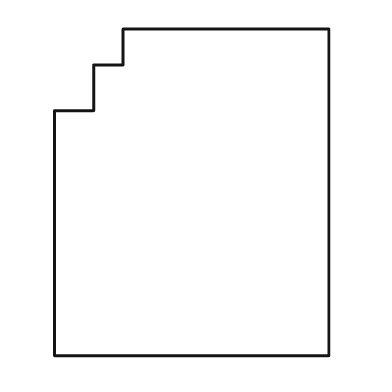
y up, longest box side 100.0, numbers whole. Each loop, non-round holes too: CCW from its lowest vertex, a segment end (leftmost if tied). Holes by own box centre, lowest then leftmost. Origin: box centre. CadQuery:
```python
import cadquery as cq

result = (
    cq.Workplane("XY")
    .moveTo(-42.0, -50.0)
    .lineTo(42.0, -50.0)
    .lineTo(42.0, 50.0)
    .lineTo(-21.0, 50.0)
    .lineTo(-21.0, 39.0)
    .lineTo(-30.0, 39.0)
    .lineTo(-30.0, 25.0)
    .lineTo(-42.0, 25.0)
    .close()
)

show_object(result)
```